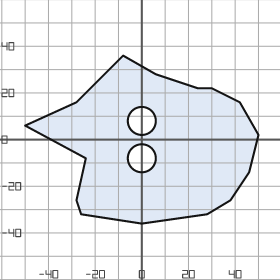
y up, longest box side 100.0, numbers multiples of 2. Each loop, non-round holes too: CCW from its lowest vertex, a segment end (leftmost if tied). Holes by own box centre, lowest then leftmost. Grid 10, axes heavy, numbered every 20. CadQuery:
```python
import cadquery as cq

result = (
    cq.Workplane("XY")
    .moveTo(0.0, -36.0)
    .lineTo(28.0, -32.0)
    .lineTo(38.0, -26.0)
    .lineTo(46.0, -14.0)
    .lineTo(50.0, 2.0)
    .lineTo(42.0, 16.0)
    .lineTo(30.0, 22.0)
    .lineTo(24.0, 22.0)
    .lineTo(6.0, 28.0)
    .lineTo(-8.0, 36.0)
    .lineTo(-28.0, 16.0)
    .lineTo(-50.0, 6.0)
    .lineTo(-24.0, -8.0)
    .lineTo(-28.0, -26.0)
    .lineTo(-26.0, -32.0)
    .close()
    .moveTo(0.0, -8.0)
    .circle(6.0)
    .moveTo(0.0, 8.0)
    .circle(6.0)
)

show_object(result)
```